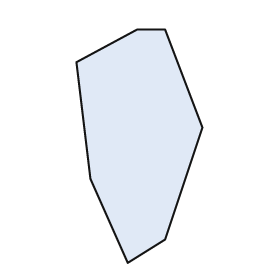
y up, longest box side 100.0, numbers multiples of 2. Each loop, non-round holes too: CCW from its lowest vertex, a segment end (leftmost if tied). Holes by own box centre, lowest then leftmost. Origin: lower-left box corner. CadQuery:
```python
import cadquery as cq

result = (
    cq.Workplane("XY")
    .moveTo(22.0, 0.0)
    .lineTo(38.0, 10.0)
    .lineTo(54.0, 58.0)
    .lineTo(38.0, 100.0)
    .lineTo(26.0, 100.0)
    .lineTo(0.0, 86.0)
    .lineTo(6.0, 36.0)
    .close()
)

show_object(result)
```